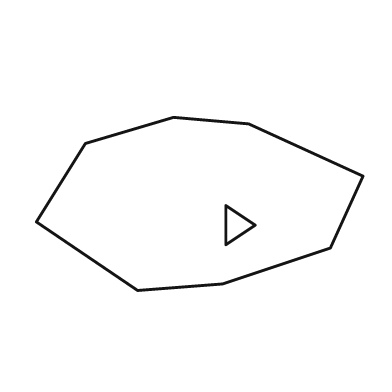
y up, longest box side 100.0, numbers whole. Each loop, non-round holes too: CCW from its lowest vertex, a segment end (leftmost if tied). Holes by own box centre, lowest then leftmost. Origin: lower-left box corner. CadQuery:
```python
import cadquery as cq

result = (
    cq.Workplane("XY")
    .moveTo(31.0, 0.0)
    .lineTo(57.0, 2.0)
    .lineTo(90.0, 13.0)
    .lineTo(100.0, 35.0)
    .lineTo(65.0, 51.0)
    .lineTo(42.0, 53.0)
    .lineTo(15.0, 45.0)
    .lineTo(0.0, 21.0)
    .close()
    .moveTo(58.0, 14.0)
    .lineTo(67.0, 20.0)
    .lineTo(58.0, 26.0)
    .close()
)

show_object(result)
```